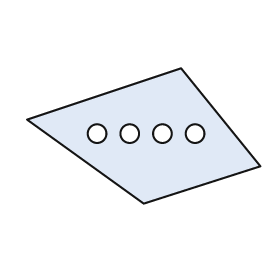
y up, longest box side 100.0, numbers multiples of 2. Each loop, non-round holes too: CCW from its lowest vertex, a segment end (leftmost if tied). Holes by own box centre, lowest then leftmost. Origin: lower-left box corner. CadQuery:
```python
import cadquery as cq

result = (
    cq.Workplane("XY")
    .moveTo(50.0, 0.0)
    .lineTo(100.0, 16.0)
    .lineTo(66.0, 58.0)
    .lineTo(0.0, 36.0)
    .close()
    .moveTo(30.0, 30.0)
    .circle(4.0)
    .moveTo(44.0, 30.0)
    .circle(4.0)
    .moveTo(58.0, 30.0)
    .circle(4.0)
    .moveTo(72.0, 30.0)
    .circle(4.0)
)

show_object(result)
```